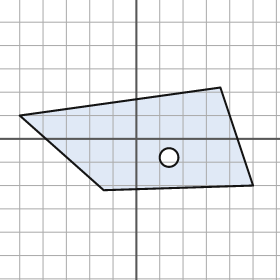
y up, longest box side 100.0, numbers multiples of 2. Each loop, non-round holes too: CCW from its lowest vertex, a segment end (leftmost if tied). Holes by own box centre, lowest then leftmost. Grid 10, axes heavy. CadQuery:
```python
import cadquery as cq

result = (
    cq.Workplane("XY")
    .moveTo(-14.0, -22.0)
    .lineTo(50.0, -20.0)
    .lineTo(36.0, 22.0)
    .lineTo(-50.0, 10.0)
    .close()
    .moveTo(14.0, -8.0)
    .circle(4.0)
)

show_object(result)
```